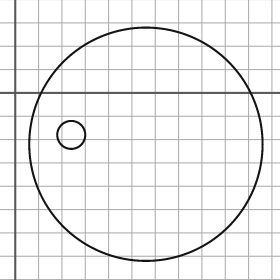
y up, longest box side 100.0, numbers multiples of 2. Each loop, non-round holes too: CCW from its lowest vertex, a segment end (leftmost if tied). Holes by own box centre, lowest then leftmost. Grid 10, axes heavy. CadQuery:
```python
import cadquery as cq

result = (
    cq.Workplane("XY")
    .moveTo(56.0, -22.0)
    .circle(50.0)
    .moveTo(24.0, -18.0)
    .circle(6.0)
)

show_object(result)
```